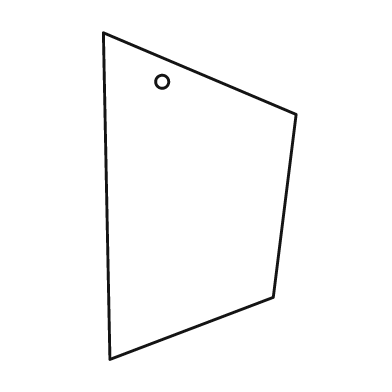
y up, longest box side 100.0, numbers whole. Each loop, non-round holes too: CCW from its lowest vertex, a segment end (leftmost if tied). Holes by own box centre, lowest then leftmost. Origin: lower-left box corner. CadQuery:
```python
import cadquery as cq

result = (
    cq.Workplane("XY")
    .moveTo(2.0, 0.0)
    .lineTo(52.0, 19.0)
    .lineTo(59.0, 75.0)
    .lineTo(0.0, 100.0)
    .close()
    .moveTo(18.0, 85.0)
    .circle(2.0)
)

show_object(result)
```